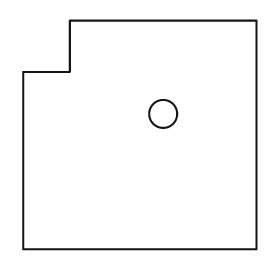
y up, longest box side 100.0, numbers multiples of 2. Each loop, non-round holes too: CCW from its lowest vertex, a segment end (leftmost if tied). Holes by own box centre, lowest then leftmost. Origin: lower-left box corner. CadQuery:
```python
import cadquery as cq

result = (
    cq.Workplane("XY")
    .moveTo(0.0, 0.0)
    .lineTo(100.0, 0.0)
    .lineTo(100.0, 98.0)
    .lineTo(20.0, 98.0)
    .lineTo(20.0, 76.0)
    .lineTo(0.0, 76.0)
    .close()
    .moveTo(60.0, 58.0)
    .circle(6.0)
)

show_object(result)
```